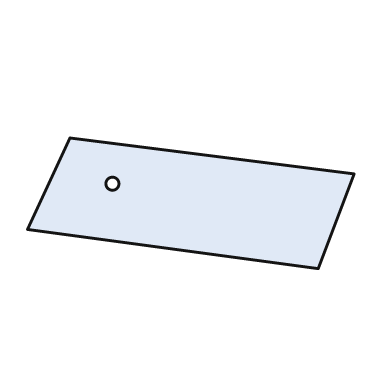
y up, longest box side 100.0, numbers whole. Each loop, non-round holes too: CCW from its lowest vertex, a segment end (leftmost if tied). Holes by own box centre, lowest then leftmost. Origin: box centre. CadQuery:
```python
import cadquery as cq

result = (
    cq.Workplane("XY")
    .moveTo(39.0, -20.0)
    .lineTo(50.0, 9.0)
    .lineTo(-37.0, 20.0)
    .lineTo(-50.0, -8.0)
    .close()
    .moveTo(-24.0, 6.0)
    .circle(2.0)
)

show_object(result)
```